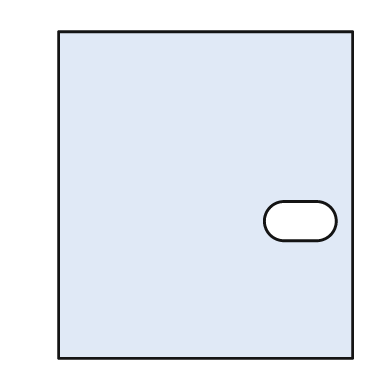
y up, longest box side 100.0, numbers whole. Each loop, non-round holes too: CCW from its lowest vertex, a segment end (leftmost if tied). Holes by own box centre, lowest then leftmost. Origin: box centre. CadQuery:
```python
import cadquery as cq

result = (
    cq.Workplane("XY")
    .moveTo(-45.0, -50.0)
    .lineTo(45.0, -50.0)
    .lineTo(45.0, 50.0)
    .lineTo(-45.0, 50.0)
    .close()
    .moveTo(24.0, -14.0)
    .lineTo(34.0, -14.0)
    .threePointArc((40.0, -8.0), (34.0, -2.0))
    .lineTo(24.0, -2.0)
    .threePointArc((18.0, -8.0), (24.0, -14.0))
    .close()
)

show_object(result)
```